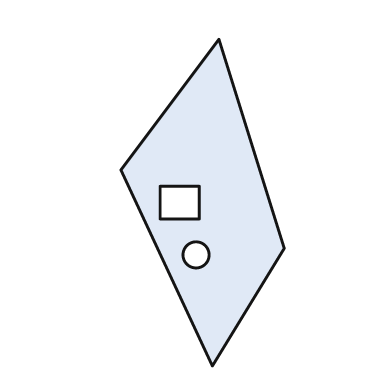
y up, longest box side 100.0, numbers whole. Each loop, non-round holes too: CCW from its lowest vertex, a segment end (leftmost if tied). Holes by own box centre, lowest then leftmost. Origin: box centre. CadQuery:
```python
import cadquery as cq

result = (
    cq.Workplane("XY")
    .moveTo(3.0, -50.0)
    .lineTo(25.0, -14.0)
    .lineTo(5.0, 50.0)
    .lineTo(-25.0, 10.0)
    .close()
    .moveTo(-2.0, -16.0)
    .circle(4.0)
    .moveTo(-13.0, -5.0)
    .lineTo(-1.0, -5.0)
    .lineTo(-1.0, 5.0)
    .lineTo(-13.0, 5.0)
    .close()
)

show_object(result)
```